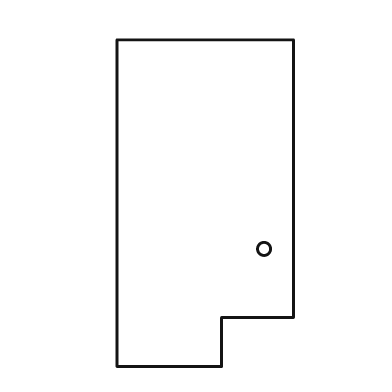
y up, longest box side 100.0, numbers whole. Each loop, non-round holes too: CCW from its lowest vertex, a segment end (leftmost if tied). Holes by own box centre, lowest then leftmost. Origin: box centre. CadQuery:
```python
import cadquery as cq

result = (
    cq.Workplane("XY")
    .moveTo(-27.0, -50.0)
    .lineTo(5.0, -50.0)
    .lineTo(5.0, -35.0)
    .lineTo(27.0, -35.0)
    .lineTo(27.0, 50.0)
    .lineTo(-27.0, 50.0)
    .close()
    .moveTo(18.0, -14.0)
    .circle(2.0)
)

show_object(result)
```